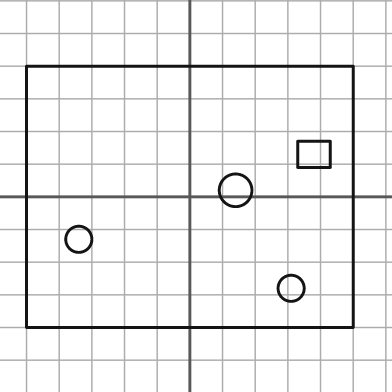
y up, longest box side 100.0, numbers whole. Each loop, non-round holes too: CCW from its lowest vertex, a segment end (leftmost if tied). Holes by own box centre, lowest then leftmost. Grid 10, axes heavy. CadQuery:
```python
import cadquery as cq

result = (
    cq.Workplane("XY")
    .moveTo(-50.0, -40.0)
    .lineTo(50.0, -40.0)
    .lineTo(50.0, 40.0)
    .lineTo(-50.0, 40.0)
    .close()
    .moveTo(31.0, -28.0)
    .circle(4.0)
    .moveTo(-34.0, -13.0)
    .circle(4.0)
    .moveTo(14.0, 2.0)
    .circle(5.0)
    .moveTo(33.0, 9.0)
    .lineTo(43.0, 9.0)
    .lineTo(43.0, 17.0)
    .lineTo(33.0, 17.0)
    .close()
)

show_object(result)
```